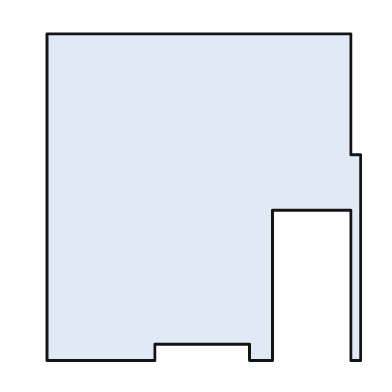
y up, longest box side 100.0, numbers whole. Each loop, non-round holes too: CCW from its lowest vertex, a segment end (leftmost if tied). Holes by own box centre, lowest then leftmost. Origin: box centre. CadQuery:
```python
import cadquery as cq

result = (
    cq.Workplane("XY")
    .moveTo(-48.0, -50.0)
    .lineTo(-15.0, -50.0)
    .lineTo(-15.0, -45.0)
    .lineTo(14.0, -45.0)
    .lineTo(14.0, -50.0)
    .lineTo(21.0, -50.0)
    .lineTo(21.0, -4.0)
    .lineTo(45.0, -4.0)
    .lineTo(45.0, -50.0)
    .lineTo(48.0, -50.0)
    .lineTo(48.0, 13.0)
    .lineTo(45.0, 13.0)
    .lineTo(45.0, 50.0)
    .lineTo(-48.0, 50.0)
    .close()
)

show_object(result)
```